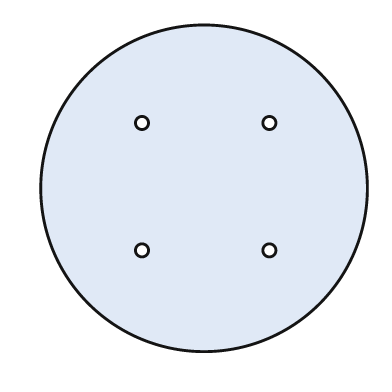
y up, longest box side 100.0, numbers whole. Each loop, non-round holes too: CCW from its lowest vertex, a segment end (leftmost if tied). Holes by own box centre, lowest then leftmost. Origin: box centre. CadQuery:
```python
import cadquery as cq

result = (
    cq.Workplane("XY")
    .moveTo(0.0, 0.0)
    .circle(50.0)
    .moveTo(-19.0, -19.0)
    .circle(2.0)
    .moveTo(20.0, -19.0)
    .circle(2.0)
    .moveTo(-19.0, 20.0)
    .circle(2.0)
    .moveTo(20.0, 20.0)
    .circle(2.0)
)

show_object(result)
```